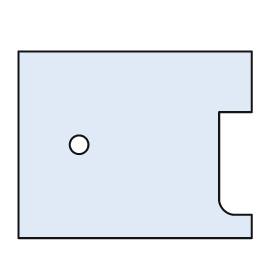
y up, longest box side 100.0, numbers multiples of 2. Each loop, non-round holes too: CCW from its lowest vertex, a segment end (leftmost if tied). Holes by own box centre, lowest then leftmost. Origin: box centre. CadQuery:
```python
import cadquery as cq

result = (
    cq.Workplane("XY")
    .moveTo(-50.0, -40.0)
    .lineTo(50.0, -40.0)
    .lineTo(50.0, -30.0)
    .lineTo(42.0, -30.0)
    .threePointArc((38.0, -28.0), (36.0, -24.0))
    .lineTo(36.0, 14.0)
    .lineTo(50.0, 14.0)
    .lineTo(50.0, 40.0)
    .lineTo(-50.0, 40.0)
    .close()
    .moveTo(-24.0, 0.0)
    .circle(4.0)
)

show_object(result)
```